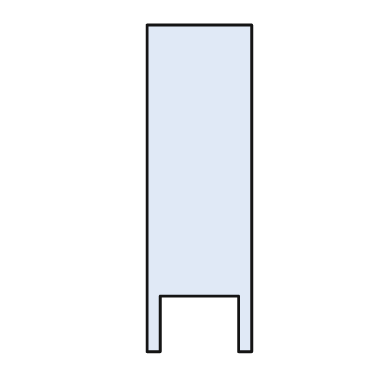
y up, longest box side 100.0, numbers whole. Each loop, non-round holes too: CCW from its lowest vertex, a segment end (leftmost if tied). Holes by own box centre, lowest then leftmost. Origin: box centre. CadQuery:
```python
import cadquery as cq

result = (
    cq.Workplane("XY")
    .moveTo(-16.0, -50.0)
    .lineTo(-12.0, -50.0)
    .lineTo(-12.0, -33.0)
    .lineTo(12.0, -33.0)
    .lineTo(12.0, -50.0)
    .lineTo(16.0, -50.0)
    .lineTo(16.0, 50.0)
    .lineTo(-16.0, 50.0)
    .close()
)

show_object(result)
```